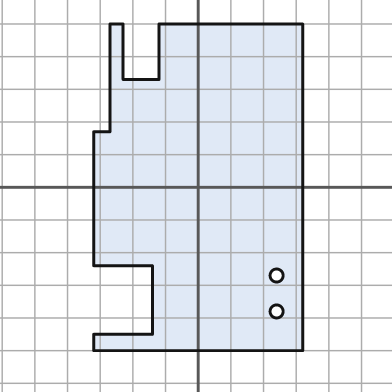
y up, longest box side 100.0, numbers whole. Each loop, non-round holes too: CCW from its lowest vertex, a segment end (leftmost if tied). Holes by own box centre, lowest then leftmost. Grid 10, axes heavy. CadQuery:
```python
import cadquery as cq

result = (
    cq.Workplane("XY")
    .moveTo(-32.0, -50.0)
    .lineTo(32.0, -50.0)
    .lineTo(32.0, 50.0)
    .lineTo(-12.0, 50.0)
    .lineTo(-12.0, 33.0)
    .lineTo(-23.0, 33.0)
    .lineTo(-23.0, 50.0)
    .lineTo(-27.0, 50.0)
    .lineTo(-27.0, 17.0)
    .lineTo(-32.0, 17.0)
    .lineTo(-32.0, -24.0)
    .lineTo(-14.0, -24.0)
    .lineTo(-14.0, -45.0)
    .lineTo(-32.0, -45.0)
    .close()
    .moveTo(24.0, -38.0)
    .circle(2.0)
    .moveTo(24.0, -27.0)
    .circle(2.0)
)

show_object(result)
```